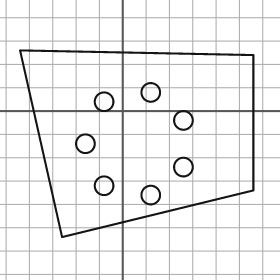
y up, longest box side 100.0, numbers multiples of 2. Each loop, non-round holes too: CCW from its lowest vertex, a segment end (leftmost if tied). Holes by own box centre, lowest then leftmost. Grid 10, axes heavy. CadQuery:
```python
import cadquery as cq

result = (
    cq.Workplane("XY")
    .moveTo(-26.0, -54.0)
    .lineTo(56.0, -34.0)
    .lineTo(56.0, 24.0)
    .lineTo(-44.0, 26.0)
    .close()
    .moveTo(12.0, -36.0)
    .circle(4.0)
    .moveTo(-8.0, -32.0)
    .circle(4.0)
    .moveTo(26.0, -24.0)
    .circle(4.0)
    .moveTo(-16.0, -14.0)
    .circle(4.0)
    .moveTo(26.0, -4.0)
    .circle(4.0)
    .moveTo(-8.0, 4.0)
    .circle(4.0)
    .moveTo(12.0, 8.0)
    .circle(4.0)
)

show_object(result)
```